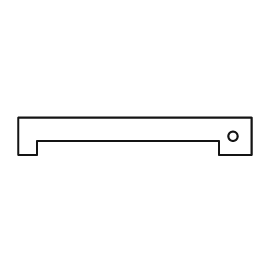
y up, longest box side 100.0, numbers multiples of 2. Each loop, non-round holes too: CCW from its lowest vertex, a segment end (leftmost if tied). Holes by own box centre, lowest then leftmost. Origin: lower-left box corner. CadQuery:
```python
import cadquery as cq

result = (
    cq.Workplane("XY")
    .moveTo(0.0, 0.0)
    .lineTo(8.0, 0.0)
    .lineTo(8.0, 6.0)
    .lineTo(86.0, 6.0)
    .lineTo(86.0, 0.0)
    .lineTo(100.0, 0.0)
    .lineTo(100.0, 16.0)
    .lineTo(0.0, 16.0)
    .close()
    .moveTo(92.0, 8.0)
    .circle(2.0)
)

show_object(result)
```